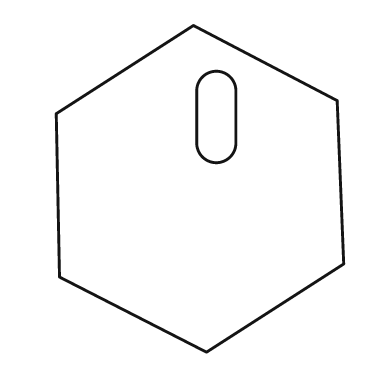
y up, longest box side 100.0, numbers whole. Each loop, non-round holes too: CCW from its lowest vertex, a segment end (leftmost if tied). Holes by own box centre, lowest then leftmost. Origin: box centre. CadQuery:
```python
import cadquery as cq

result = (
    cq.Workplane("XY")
    .moveTo(2.0, -50.0)
    .lineTo(44.0, -23.0)
    .lineTo(42.0, 27.0)
    .lineTo(-2.0, 50.0)
    .lineTo(-44.0, 23.0)
    .lineTo(-43.0, -27.0)
    .close()
    .moveTo(-1.0, 14.0)
    .threePointArc((5.0, 8.0), (11.0, 14.0))
    .lineTo(11.0, 30.0)
    .threePointArc((5.0, 36.0), (-1.0, 30.0))
    .close()
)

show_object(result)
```